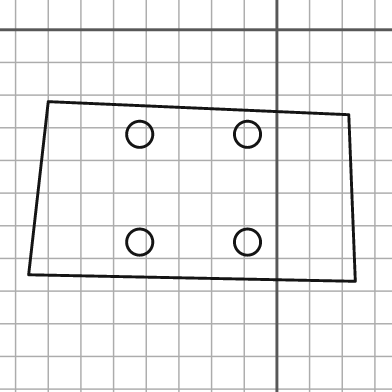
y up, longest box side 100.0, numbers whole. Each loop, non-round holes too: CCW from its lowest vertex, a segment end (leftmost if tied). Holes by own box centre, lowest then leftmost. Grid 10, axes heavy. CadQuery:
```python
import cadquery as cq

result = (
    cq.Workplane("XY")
    .moveTo(24.0, -77.0)
    .lineTo(22.0, -26.0)
    .lineTo(-70.0, -22.0)
    .lineTo(-76.0, -75.0)
    .close()
    .moveTo(-42.0, -65.0)
    .circle(4.0)
    .moveTo(-9.0, -65.0)
    .circle(4.0)
    .moveTo(-42.0, -32.0)
    .circle(4.0)
    .moveTo(-9.0, -32.0)
    .circle(4.0)
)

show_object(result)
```